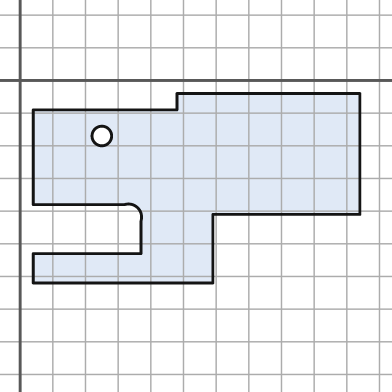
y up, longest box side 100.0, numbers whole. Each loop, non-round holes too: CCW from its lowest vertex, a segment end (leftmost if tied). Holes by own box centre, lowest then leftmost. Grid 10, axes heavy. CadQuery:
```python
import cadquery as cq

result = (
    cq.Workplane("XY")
    .moveTo(4.0, -62.0)
    .lineTo(59.0, -62.0)
    .lineTo(59.0, -41.0)
    .lineTo(104.0, -41.0)
    .lineTo(104.0, -4.0)
    .lineTo(48.0, -4.0)
    .lineTo(48.0, -9.0)
    .lineTo(4.0, -9.0)
    .lineTo(4.0, -38.0)
    .lineTo(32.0, -38.0)
    .threePointArc((36.0, -39.0), (37.0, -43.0))
    .lineTo(37.0, -53.0)
    .lineTo(4.0, -53.0)
    .close()
    .moveTo(25.0, -17.0)
    .circle(3.0)
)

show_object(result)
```